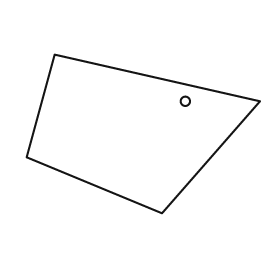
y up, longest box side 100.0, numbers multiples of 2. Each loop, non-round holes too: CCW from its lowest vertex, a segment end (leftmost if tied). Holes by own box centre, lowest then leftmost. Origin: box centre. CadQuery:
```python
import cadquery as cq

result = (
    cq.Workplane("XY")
    .moveTo(8.0, -34.0)
    .lineTo(50.0, 14.0)
    .lineTo(-38.0, 34.0)
    .lineTo(-50.0, -10.0)
    .close()
    .moveTo(18.0, 14.0)
    .circle(2.0)
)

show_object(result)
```